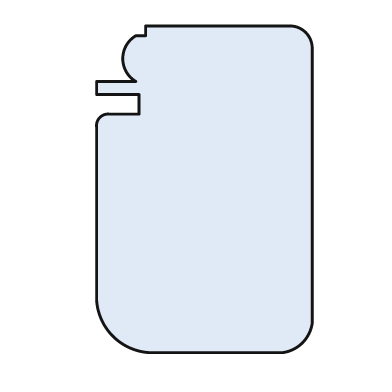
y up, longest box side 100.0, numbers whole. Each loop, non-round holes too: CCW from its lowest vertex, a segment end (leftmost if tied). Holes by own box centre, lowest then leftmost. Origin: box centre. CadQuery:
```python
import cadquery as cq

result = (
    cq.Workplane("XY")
    .moveTo(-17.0, -50.0)
    .lineTo(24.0, -50.0)
    .threePointArc((30.0, -47.0), (33.0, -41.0))
    .lineTo(33.0, 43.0)
    .threePointArc((31.0, 48.0), (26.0, 50.0))
    .lineTo(-18.0, 50.0)
    .lineTo(-18.0, 47.0)
    .lineTo(-21.0, 47.0)
    .threePointArc((-25.0, 40.0), (-21.0, 33.0))
    .lineTo(-33.0, 33.0)
    .lineTo(-33.0, 29.0)
    .lineTo(-20.0, 29.0)
    .lineTo(-20.0, 23.0)
    .lineTo(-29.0, 23.0)
    .threePointArc((-32.0, 22.0), (-33.0, 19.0))
    .lineTo(-33.0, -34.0)
    .threePointArc((-28.0, -45.0), (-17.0, -50.0))
    .close()
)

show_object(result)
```